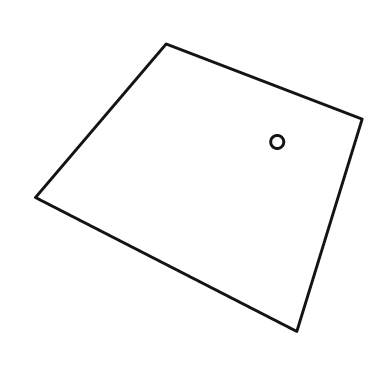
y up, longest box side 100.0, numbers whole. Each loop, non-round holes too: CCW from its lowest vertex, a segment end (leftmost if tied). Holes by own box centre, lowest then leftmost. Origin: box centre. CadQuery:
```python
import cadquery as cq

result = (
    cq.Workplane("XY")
    .moveTo(30.0, -44.0)
    .lineTo(50.0, 21.0)
    .lineTo(-10.0, 44.0)
    .lineTo(-50.0, -3.0)
    .close()
    .moveTo(24.0, 14.0)
    .circle(2.0)
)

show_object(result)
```